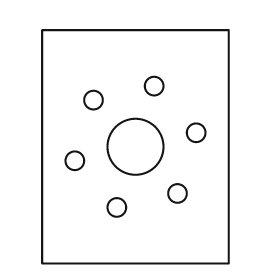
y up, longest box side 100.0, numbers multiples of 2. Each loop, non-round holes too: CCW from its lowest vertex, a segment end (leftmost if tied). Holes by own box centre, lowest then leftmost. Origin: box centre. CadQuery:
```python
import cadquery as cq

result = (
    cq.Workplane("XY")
    .moveTo(-40.0, -50.0)
    .lineTo(40.0, -50.0)
    .lineTo(40.0, 50.0)
    .lineTo(-40.0, 50.0)
    .close()
    .moveTo(-8.0, -26.0)
    .circle(4.0)
    .moveTo(18.0, -20.0)
    .circle(4.0)
    .moveTo(-26.0, -6.0)
    .circle(4.0)
    .moveTo(0.0, 0.0)
    .circle(12.0)
    .moveTo(26.0, 6.0)
    .circle(4.0)
    .moveTo(-18.0, 20.0)
    .circle(4.0)
    .moveTo(8.0, 26.0)
    .circle(4.0)
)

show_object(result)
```